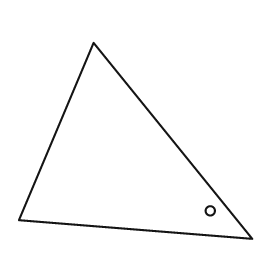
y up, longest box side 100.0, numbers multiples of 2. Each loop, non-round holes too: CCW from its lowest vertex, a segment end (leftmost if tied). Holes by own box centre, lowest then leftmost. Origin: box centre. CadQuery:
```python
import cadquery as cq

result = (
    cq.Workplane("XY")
    .moveTo(50.0, -42.0)
    .lineTo(-18.0, 42.0)
    .lineTo(-50.0, -34.0)
    .close()
    .moveTo(32.0, -30.0)
    .circle(2.0)
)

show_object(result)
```